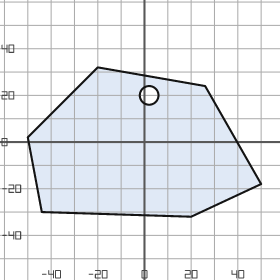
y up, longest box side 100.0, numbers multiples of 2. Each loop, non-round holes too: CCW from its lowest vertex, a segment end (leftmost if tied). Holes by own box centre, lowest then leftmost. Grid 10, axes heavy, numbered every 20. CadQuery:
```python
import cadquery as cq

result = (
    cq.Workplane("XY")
    .moveTo(20.0, -32.0)
    .lineTo(50.0, -18.0)
    .lineTo(26.0, 24.0)
    .lineTo(-20.0, 32.0)
    .lineTo(-50.0, 2.0)
    .lineTo(-44.0, -30.0)
    .close()
    .moveTo(2.0, 20.0)
    .circle(4.0)
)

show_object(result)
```